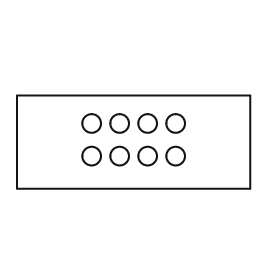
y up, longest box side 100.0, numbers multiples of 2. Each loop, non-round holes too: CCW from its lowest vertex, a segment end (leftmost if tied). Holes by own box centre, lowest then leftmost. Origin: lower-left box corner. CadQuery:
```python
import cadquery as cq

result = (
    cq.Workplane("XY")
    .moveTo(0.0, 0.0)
    .lineTo(100.0, 0.0)
    .lineTo(100.0, 40.0)
    .lineTo(0.0, 40.0)
    .close()
    .moveTo(32.0, 14.0)
    .circle(4.0)
    .moveTo(44.0, 14.0)
    .circle(4.0)
    .moveTo(56.0, 14.0)
    .circle(4.0)
    .moveTo(68.0, 14.0)
    .circle(4.0)
    .moveTo(32.0, 28.0)
    .circle(4.0)
    .moveTo(44.0, 28.0)
    .circle(4.0)
    .moveTo(56.0, 28.0)
    .circle(4.0)
    .moveTo(68.0, 28.0)
    .circle(4.0)
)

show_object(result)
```